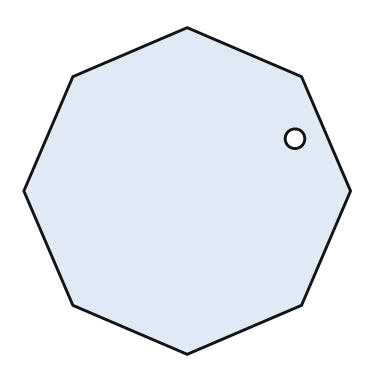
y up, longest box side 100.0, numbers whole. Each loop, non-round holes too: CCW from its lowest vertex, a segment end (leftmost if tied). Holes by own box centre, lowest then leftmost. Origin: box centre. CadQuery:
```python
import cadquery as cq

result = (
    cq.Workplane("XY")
    .moveTo(0.0, -50.0)
    .lineTo(35.0, -35.0)
    .lineTo(50.0, 0.0)
    .lineTo(35.0, 35.0)
    .lineTo(0.0, 50.0)
    .lineTo(-35.0, 35.0)
    .lineTo(-50.0, 0.0)
    .lineTo(-35.0, -35.0)
    .close()
    .moveTo(33.0, 16.0)
    .circle(3.0)
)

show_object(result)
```